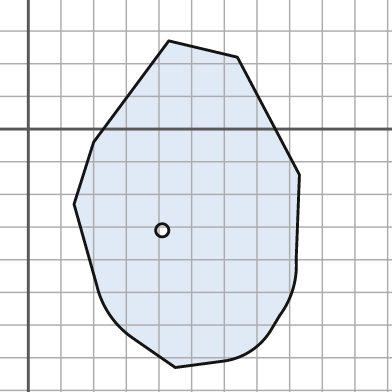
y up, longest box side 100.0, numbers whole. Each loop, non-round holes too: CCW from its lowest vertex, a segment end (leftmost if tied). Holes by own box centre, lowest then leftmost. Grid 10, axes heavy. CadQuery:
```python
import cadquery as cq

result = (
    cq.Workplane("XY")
    .moveTo(45.0, -73.0)
    .lineTo(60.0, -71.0)
    .threePointArc((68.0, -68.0), (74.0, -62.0))
    .lineTo(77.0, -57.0)
    .threePointArc((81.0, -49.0), (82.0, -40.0))
    .lineTo(83.0, -14.0)
    .lineTo(64.0, 22.0)
    .lineTo(43.0, 27.0)
    .lineTo(20.0, -4.0)
    .lineTo(14.0, -23.0)
    .lineTo(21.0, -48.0)
    .threePointArc((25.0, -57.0), (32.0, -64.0))
    .close()
    .moveTo(41.0, -31.0)
    .circle(2.0)
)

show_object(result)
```